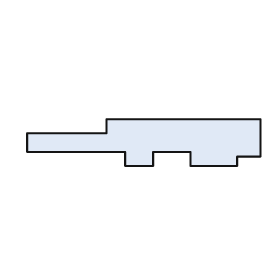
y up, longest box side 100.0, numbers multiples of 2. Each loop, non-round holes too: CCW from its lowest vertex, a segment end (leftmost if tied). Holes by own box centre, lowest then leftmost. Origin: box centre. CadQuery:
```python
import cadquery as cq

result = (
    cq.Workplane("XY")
    .moveTo(-8.0, -10.0)
    .lineTo(4.0, -10.0)
    .lineTo(4.0, -4.0)
    .lineTo(20.0, -4.0)
    .lineTo(20.0, -10.0)
    .lineTo(40.0, -10.0)
    .lineTo(40.0, -6.0)
    .lineTo(50.0, -6.0)
    .lineTo(50.0, 10.0)
    .lineTo(-16.0, 10.0)
    .lineTo(-16.0, 4.0)
    .lineTo(-50.0, 4.0)
    .lineTo(-50.0, -4.0)
    .lineTo(-8.0, -4.0)
    .close()
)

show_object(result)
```